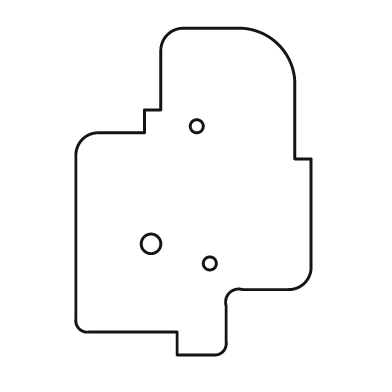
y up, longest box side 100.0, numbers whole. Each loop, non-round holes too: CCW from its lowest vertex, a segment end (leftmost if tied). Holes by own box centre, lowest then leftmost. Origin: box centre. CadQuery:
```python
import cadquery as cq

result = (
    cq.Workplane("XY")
    .moveTo(-5.0, -50.0)
    .lineTo(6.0, -50.0)
    .threePointArc((9.0, -49.0), (10.0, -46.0))
    .lineTo(10.0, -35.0)
    .threePointArc((11.0, -31.0), (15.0, -30.0))
    .lineTo(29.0, -30.0)
    .threePointArc((34.0, -28.0), (36.0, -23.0))
    .lineTo(36.0, 10.0)
    .lineTo(31.0, 10.0)
    .lineTo(31.0, 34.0)
    .threePointArc((26.0, 45.0), (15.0, 50.0))
    .lineTo(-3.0, 50.0)
    .threePointArc((-8.0, 48.0), (-10.0, 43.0))
    .lineTo(-10.0, 25.0)
    .lineTo(-15.0, 25.0)
    .lineTo(-15.0, 18.0)
    .lineTo(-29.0, 18.0)
    .threePointArc((-34.0, 16.0), (-36.0, 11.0))
    .lineTo(-36.0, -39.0)
    .threePointArc((-35.0, -42.0), (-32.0, -43.0))
    .lineTo(-5.0, -43.0)
    .close()
    .moveTo(5.0, -22.0)
    .circle(2.0)
    .moveTo(-13.0, -16.0)
    .circle(3.0)
    .moveTo(1.0, 20.0)
    .circle(2.0)
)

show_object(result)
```